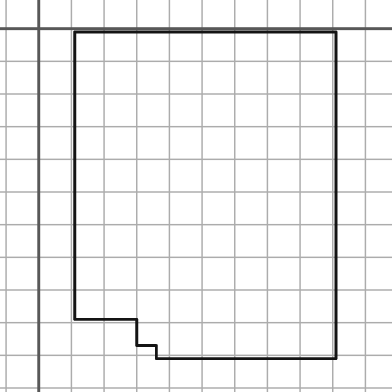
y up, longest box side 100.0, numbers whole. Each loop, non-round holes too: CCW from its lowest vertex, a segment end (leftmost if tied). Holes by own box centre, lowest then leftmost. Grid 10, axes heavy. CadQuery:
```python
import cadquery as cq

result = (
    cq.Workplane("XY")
    .moveTo(36.0, -101.0)
    .lineTo(91.0, -101.0)
    .lineTo(91.0, -1.0)
    .lineTo(11.0, -1.0)
    .lineTo(11.0, -89.0)
    .lineTo(30.0, -89.0)
    .lineTo(30.0, -97.0)
    .lineTo(36.0, -97.0)
    .close()
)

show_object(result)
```